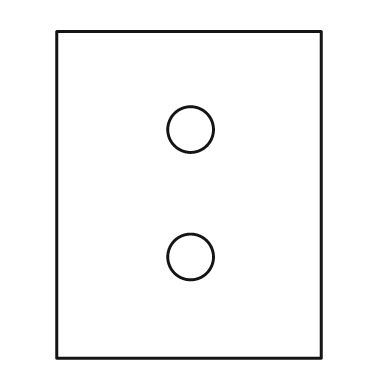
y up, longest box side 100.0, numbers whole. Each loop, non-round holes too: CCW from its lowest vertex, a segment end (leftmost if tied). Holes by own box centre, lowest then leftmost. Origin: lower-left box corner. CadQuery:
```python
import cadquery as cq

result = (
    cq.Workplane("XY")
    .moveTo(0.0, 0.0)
    .lineTo(81.0, 0.0)
    .lineTo(81.0, 100.0)
    .lineTo(0.0, 100.0)
    .close()
    .moveTo(41.0, 31.0)
    .circle(7.0)
    .moveTo(41.0, 70.0)
    .circle(7.0)
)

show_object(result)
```